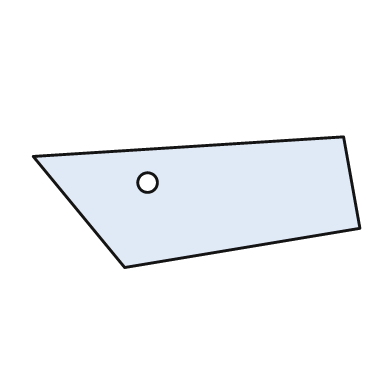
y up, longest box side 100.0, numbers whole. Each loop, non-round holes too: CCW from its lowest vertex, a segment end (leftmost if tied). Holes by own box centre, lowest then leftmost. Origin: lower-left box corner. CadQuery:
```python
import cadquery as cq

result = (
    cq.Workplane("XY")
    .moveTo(28.0, 0.0)
    .lineTo(100.0, 12.0)
    .lineTo(95.0, 40.0)
    .lineTo(0.0, 34.0)
    .close()
    .moveTo(35.0, 26.0)
    .circle(3.0)
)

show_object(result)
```